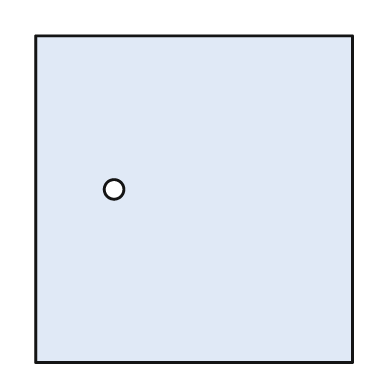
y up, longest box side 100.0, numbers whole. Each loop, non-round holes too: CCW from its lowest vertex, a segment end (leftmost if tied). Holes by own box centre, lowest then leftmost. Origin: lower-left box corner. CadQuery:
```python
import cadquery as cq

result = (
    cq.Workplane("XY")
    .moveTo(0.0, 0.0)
    .lineTo(97.0, 0.0)
    .lineTo(97.0, 100.0)
    .lineTo(0.0, 100.0)
    .close()
    .moveTo(24.0, 53.0)
    .circle(3.0)
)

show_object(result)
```